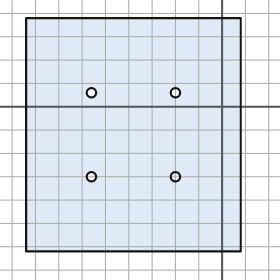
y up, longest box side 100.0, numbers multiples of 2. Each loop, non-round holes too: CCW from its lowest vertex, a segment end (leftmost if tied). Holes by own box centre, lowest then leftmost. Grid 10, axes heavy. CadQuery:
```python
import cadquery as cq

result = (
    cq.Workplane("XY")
    .moveTo(-84.0, -62.0)
    .lineTo(8.0, -62.0)
    .lineTo(8.0, 38.0)
    .lineTo(-84.0, 38.0)
    .close()
    .moveTo(-56.0, -30.0)
    .circle(2.0)
    .moveTo(-20.0, -30.0)
    .circle(2.0)
    .moveTo(-56.0, 6.0)
    .circle(2.0)
    .moveTo(-20.0, 6.0)
    .circle(2.0)
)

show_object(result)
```